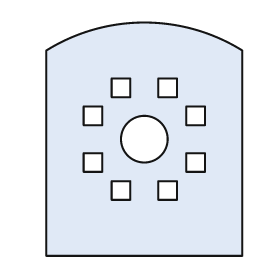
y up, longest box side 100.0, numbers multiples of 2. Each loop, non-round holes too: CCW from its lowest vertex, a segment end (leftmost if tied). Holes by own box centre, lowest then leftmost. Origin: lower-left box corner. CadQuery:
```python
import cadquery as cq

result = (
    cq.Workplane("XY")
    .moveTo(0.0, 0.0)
    .lineTo(84.0, 0.0)
    .lineTo(84.0, 88.0)
    .threePointArc((42.0, 100.0), (0.0, 88.0))
    .close()
    .moveTo(28.0, 24.0)
    .lineTo(36.0, 24.0)
    .lineTo(36.0, 32.0)
    .lineTo(28.0, 32.0)
    .close()
    .moveTo(48.0, 24.0)
    .lineTo(56.0, 24.0)
    .lineTo(56.0, 32.0)
    .lineTo(48.0, 32.0)
    .close()
    .moveTo(16.0, 36.0)
    .lineTo(24.0, 36.0)
    .lineTo(24.0, 44.0)
    .lineTo(16.0, 44.0)
    .close()
    .moveTo(60.0, 36.0)
    .lineTo(68.0, 36.0)
    .lineTo(68.0, 44.0)
    .lineTo(60.0, 44.0)
    .close()
    .moveTo(42.0, 50.0)
    .circle(10.0)
    .moveTo(16.0, 56.0)
    .lineTo(24.0, 56.0)
    .lineTo(24.0, 64.0)
    .lineTo(16.0, 64.0)
    .close()
    .moveTo(60.0, 56.0)
    .lineTo(68.0, 56.0)
    .lineTo(68.0, 64.0)
    .lineTo(60.0, 64.0)
    .close()
    .moveTo(28.0, 68.0)
    .lineTo(36.0, 68.0)
    .lineTo(36.0, 76.0)
    .lineTo(28.0, 76.0)
    .close()
    .moveTo(48.0, 68.0)
    .lineTo(56.0, 68.0)
    .lineTo(56.0, 76.0)
    .lineTo(48.0, 76.0)
    .close()
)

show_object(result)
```